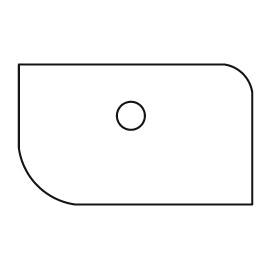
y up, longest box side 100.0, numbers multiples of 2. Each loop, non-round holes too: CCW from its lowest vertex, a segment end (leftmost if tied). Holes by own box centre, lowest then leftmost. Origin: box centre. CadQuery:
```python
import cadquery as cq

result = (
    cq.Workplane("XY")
    .moveTo(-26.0, -30.0)
    .lineTo(50.0, -30.0)
    .lineTo(50.0, 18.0)
    .threePointArc((46.0, 26.0), (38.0, 30.0))
    .lineTo(-50.0, 30.0)
    .lineTo(-50.0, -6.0)
    .threePointArc((-42.0, -22.0), (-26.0, -30.0))
    .close()
    .moveTo(-2.0, 8.0)
    .circle(6.0)
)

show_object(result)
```